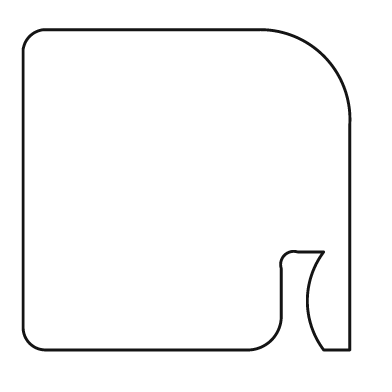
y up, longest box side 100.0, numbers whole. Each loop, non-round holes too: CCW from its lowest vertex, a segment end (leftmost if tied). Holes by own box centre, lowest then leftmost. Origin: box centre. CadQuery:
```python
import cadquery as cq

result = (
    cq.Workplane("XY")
    .moveTo(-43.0, -49.0)
    .lineTo(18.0, -49.0)
    .threePointArc((26.0, -46.0), (29.0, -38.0))
    .lineTo(29.0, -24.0)
    .threePointArc((30.0, -20.0), (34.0, -19.0))
    .lineTo(42.0, -19.0)
    .threePointArc((37.0, -34.0), (42.0, -49.0))
    .lineTo(50.0, -49.0)
    .lineTo(50.0, 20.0)
    .threePointArc((42.0, 41.0), (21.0, 49.0))
    .lineTo(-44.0, 49.0)
    .threePointArc((-48.0, 47.0), (-50.0, 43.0))
    .lineTo(-50.0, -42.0)
    .threePointArc((-48.0, -47.0), (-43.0, -49.0))
    .close()
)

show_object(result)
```